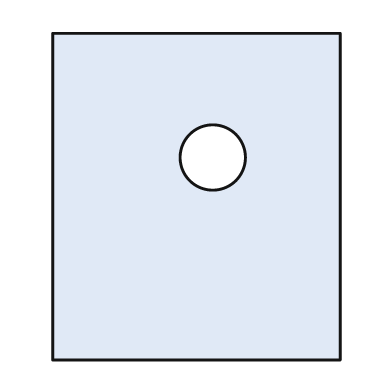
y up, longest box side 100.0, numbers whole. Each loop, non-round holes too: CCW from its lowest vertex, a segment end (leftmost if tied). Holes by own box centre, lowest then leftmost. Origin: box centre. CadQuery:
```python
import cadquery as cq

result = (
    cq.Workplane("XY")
    .moveTo(-44.0, -50.0)
    .lineTo(44.0, -50.0)
    .lineTo(44.0, 50.0)
    .lineTo(-44.0, 50.0)
    .close()
    .moveTo(5.0, 12.0)
    .circle(10.0)
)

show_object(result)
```